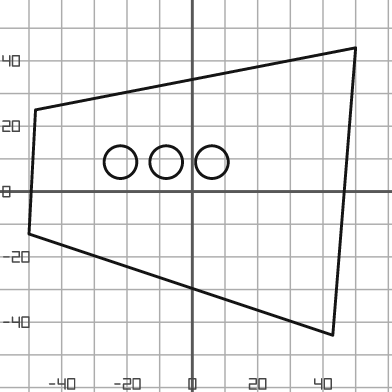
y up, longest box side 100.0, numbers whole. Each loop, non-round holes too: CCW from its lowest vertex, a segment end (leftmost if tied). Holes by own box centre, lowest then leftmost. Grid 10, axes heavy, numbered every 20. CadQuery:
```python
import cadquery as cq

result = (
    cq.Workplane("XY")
    .moveTo(43.0, -44.0)
    .lineTo(50.0, 44.0)
    .lineTo(-48.0, 25.0)
    .lineTo(-50.0, -13.0)
    .close()
    .moveTo(-22.0, 9.0)
    .circle(5.0)
    .moveTo(-8.0, 9.0)
    .circle(5.0)
    .moveTo(6.0, 9.0)
    .circle(5.0)
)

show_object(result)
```